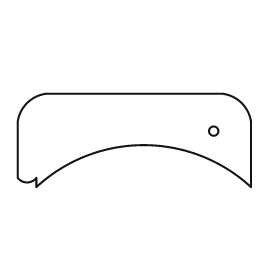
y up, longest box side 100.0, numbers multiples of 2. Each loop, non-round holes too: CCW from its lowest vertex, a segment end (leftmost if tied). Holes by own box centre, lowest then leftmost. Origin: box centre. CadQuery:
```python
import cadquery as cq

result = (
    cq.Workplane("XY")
    .moveTo(-42.0, -20.0)
    .threePointArc((4.0, -2.0), (50.0, -20.0))
    .lineTo(50.0, 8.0)
    .threePointArc((46.0, 16.0), (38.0, 20.0))
    .lineTo(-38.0, 20.0)
    .threePointArc((-46.0, 16.0), (-50.0, 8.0))
    .lineTo(-50.0, -16.0)
    .threePointArc((-46.0, -18.0), (-42.0, -16.0))
    .close()
    .moveTo(34.0, 4.0)
    .circle(2.0)
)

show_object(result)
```